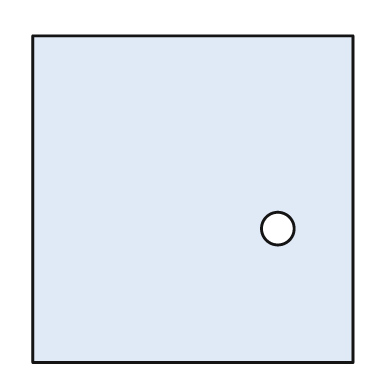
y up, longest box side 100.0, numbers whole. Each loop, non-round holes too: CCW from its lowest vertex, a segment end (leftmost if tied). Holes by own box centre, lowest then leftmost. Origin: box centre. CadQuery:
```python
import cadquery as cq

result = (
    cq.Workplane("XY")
    .moveTo(-49.0, -50.0)
    .lineTo(49.0, -50.0)
    .lineTo(49.0, 50.0)
    .lineTo(-49.0, 50.0)
    .close()
    .moveTo(26.0, -9.0)
    .circle(5.0)
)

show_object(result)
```